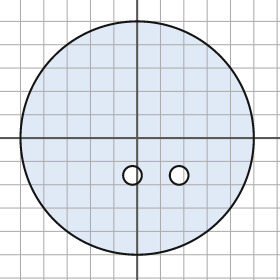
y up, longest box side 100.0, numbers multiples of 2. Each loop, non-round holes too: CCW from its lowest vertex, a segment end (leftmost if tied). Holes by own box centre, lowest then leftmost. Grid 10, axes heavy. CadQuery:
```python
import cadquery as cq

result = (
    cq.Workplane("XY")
    .moveTo(0.0, 0.0)
    .circle(50.0)
    .moveTo(-2.0, -16.0)
    .circle(4.0)
    .moveTo(18.0, -16.0)
    .circle(4.0)
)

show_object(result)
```